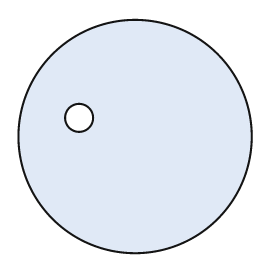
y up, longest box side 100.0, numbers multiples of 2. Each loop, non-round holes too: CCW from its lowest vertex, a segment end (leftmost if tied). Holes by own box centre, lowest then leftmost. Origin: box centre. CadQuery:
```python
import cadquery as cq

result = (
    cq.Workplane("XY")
    .moveTo(0.0, 0.0)
    .circle(50.0)
    .moveTo(-24.0, 8.0)
    .circle(6.0)
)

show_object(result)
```